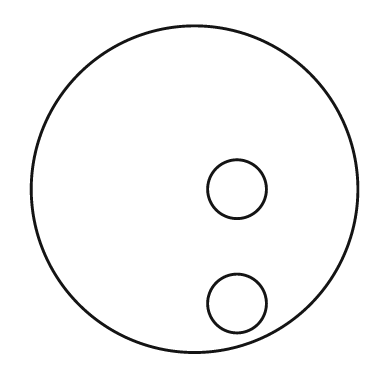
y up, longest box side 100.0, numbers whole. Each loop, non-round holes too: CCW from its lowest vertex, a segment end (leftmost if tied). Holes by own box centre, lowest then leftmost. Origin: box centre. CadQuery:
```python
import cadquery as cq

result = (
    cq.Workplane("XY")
    .moveTo(0.0, 0.0)
    .circle(50.0)
    .moveTo(13.0, -35.0)
    .circle(9.0)
    .moveTo(13.0, 0.0)
    .circle(9.0)
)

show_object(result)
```